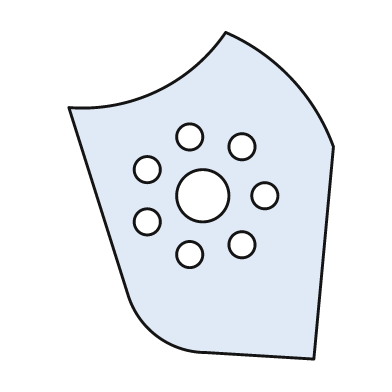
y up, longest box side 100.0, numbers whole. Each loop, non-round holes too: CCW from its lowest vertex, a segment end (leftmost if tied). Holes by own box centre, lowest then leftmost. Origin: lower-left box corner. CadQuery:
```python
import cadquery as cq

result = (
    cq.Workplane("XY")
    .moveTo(75.0, 0.0)
    .lineTo(81.0, 65.0)
    .threePointArc((68.0, 86.0), (48.0, 100.0))
    .threePointArc((27.0, 82.0), (0.0, 77.0))
    .lineTo(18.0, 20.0)
    .threePointArc((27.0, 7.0), (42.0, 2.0))
    .close()
    .moveTo(37.0, 32.0)
    .circle(4.0)
    .moveTo(53.0, 35.0)
    .circle(4.0)
    .moveTo(24.0, 42.0)
    .circle(4.0)
    .moveTo(41.0, 50.0)
    .circle(8.0)
    .moveTo(60.0, 50.0)
    .circle(4.0)
    .moveTo(24.0, 58.0)
    .circle(4.0)
    .moveTo(53.0, 65.0)
    .circle(4.0)
    .moveTo(37.0, 68.0)
    .circle(4.0)
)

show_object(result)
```